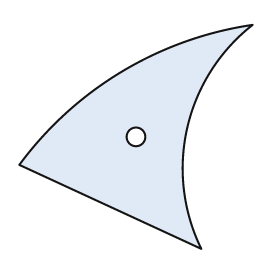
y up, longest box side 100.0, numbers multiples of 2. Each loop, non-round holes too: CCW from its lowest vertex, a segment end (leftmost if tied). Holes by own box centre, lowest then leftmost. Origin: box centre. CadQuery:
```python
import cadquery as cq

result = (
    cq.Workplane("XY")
    .moveTo(28.0, -48.0)
    .threePointArc((22.0, 4.0), (50.0, 48.0))
    .threePointArc((-6.0, 28.0), (-50.0, -12.0))
    .close()
    .moveTo(0.0, 0.0)
    .circle(4.0)
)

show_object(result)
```